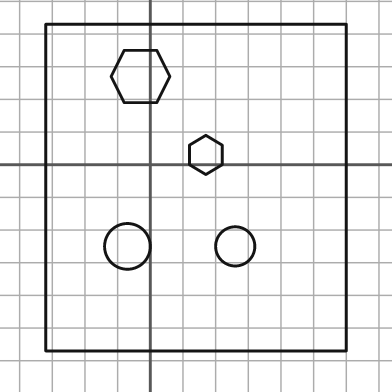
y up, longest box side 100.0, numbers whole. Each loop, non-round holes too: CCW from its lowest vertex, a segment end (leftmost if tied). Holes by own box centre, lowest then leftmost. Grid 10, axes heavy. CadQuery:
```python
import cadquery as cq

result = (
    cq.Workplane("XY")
    .moveTo(-32.0, -57.0)
    .lineTo(60.0, -57.0)
    .lineTo(60.0, 43.0)
    .lineTo(-32.0, 43.0)
    .close()
    .moveTo(-7.0, -25.0)
    .circle(7.0)
    .moveTo(26.0, -25.0)
    .circle(6.0)
    .moveTo(17.0, -3.0)
    .lineTo(22.0, 0.0)
    .lineTo(22.0, 6.0)
    .lineTo(17.0, 9.0)
    .lineTo(12.0, 6.0)
    .lineTo(12.0, 0.0)
    .close()
    .moveTo(-8.0, 19.0)
    .lineTo(2.0, 19.0)
    .lineTo(6.0, 27.0)
    .lineTo(2.0, 35.0)
    .lineTo(-8.0, 35.0)
    .lineTo(-12.0, 27.0)
    .close()
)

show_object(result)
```